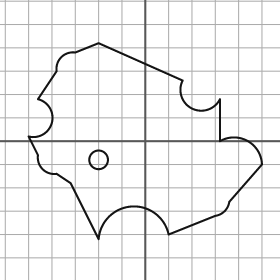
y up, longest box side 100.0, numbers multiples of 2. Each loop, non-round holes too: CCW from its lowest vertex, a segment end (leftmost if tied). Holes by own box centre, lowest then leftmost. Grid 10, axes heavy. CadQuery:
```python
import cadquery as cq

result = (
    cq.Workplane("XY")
    .moveTo(-20.0, -42.0)
    .threePointArc((-6.0, -28.0), (10.0, -40.0))
    .lineTo(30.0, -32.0)
    .threePointArc((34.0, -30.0), (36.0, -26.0))
    .lineTo(50.0, -10.0)
    .threePointArc((44.0, 0.0), (32.0, 0.0))
    .lineTo(32.0, 18.0)
    .threePointArc((20.0, 14.0), (16.0, 26.0))
    .lineTo(-20.0, 42.0)
    .lineTo(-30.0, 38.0)
    .threePointArc((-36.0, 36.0), (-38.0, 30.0))
    .lineTo(-46.0, 18.0)
    .threePointArc((-40.0, 8.0), (-50.0, 2.0))
    .lineTo(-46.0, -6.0)
    .threePointArc((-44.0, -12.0), (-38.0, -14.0))
    .lineTo(-32.0, -18.0)
    .close()
    .moveTo(-20.0, -8.0)
    .circle(4.0)
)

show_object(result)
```